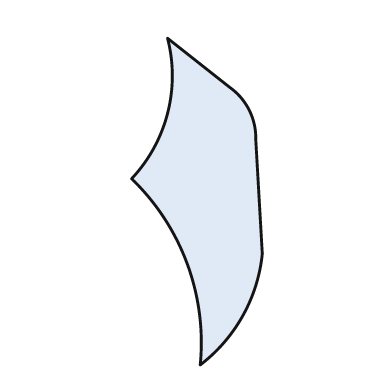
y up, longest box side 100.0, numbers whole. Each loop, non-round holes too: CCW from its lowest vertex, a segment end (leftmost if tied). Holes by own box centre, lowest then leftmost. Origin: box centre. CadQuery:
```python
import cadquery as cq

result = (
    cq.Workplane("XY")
    .moveTo(1.0, -50.0)
    .threePointArc((14.0, -35.0), (20.0, -16.0))
    .lineTo(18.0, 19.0)
    .threePointArc((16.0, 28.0), (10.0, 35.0))
    .lineTo(-9.0, 50.0)
    .threePointArc((-9.0, 27.0), (-20.0, 7.0))
    .threePointArc((-3.0, -19.0), (1.0, -50.0))
    .close()
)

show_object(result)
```